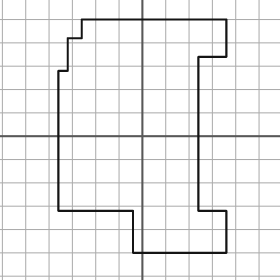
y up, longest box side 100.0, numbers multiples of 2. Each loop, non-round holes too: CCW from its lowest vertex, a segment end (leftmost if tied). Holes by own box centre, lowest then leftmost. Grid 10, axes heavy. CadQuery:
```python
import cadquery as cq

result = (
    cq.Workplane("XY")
    .moveTo(-4.0, -50.0)
    .lineTo(36.0, -50.0)
    .lineTo(36.0, -32.0)
    .lineTo(24.0, -32.0)
    .lineTo(24.0, 34.0)
    .lineTo(36.0, 34.0)
    .lineTo(36.0, 50.0)
    .lineTo(-26.0, 50.0)
    .lineTo(-26.0, 42.0)
    .lineTo(-32.0, 42.0)
    .lineTo(-32.0, 28.0)
    .lineTo(-36.0, 28.0)
    .lineTo(-36.0, -32.0)
    .lineTo(-4.0, -32.0)
    .close()
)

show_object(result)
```